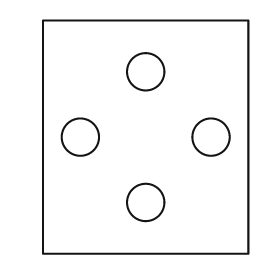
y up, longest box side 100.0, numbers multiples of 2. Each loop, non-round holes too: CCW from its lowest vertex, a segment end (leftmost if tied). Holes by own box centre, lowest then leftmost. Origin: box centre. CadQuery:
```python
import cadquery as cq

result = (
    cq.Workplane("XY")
    .moveTo(-44.0, -50.0)
    .lineTo(44.0, -50.0)
    .lineTo(44.0, 50.0)
    .lineTo(-44.0, 50.0)
    .close()
    .moveTo(0.0, -28.0)
    .circle(8.0)
    .moveTo(-28.0, 0.0)
    .circle(8.0)
    .moveTo(28.0, 0.0)
    .circle(8.0)
    .moveTo(0.0, 28.0)
    .circle(8.0)
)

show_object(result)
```